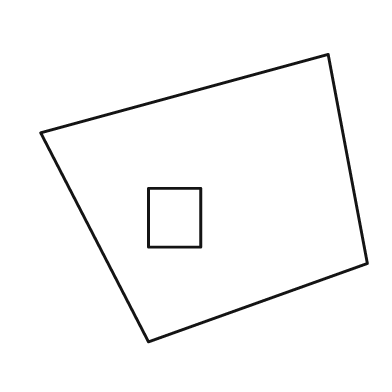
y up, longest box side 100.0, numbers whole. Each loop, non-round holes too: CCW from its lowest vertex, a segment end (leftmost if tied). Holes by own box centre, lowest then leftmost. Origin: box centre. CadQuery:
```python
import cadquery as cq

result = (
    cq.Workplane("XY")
    .moveTo(-17.0, -44.0)
    .lineTo(50.0, -20.0)
    .lineTo(38.0, 44.0)
    .lineTo(-50.0, 20.0)
    .close()
    .moveTo(-17.0, -15.0)
    .lineTo(-1.0, -15.0)
    .lineTo(-1.0, 3.0)
    .lineTo(-17.0, 3.0)
    .close()
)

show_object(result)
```